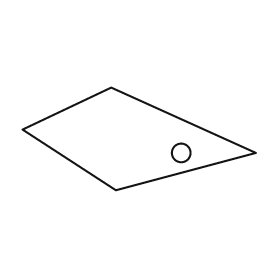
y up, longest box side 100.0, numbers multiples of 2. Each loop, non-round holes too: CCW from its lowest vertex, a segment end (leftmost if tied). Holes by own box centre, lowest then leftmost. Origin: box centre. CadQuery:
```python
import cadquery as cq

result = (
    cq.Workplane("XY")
    .moveTo(-10.0, -22.0)
    .lineTo(50.0, -6.0)
    .lineTo(-12.0, 22.0)
    .lineTo(-50.0, 4.0)
    .close()
    .moveTo(18.0, -6.0)
    .circle(4.0)
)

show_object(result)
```